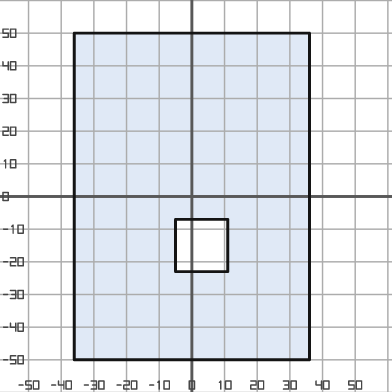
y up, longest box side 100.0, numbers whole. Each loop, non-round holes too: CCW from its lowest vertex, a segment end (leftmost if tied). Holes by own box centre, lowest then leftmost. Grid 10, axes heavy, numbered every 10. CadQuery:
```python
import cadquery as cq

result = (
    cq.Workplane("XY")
    .moveTo(-36.0, -50.0)
    .lineTo(36.0, -50.0)
    .lineTo(36.0, 50.0)
    .lineTo(-36.0, 50.0)
    .close()
    .moveTo(-5.0, -23.0)
    .lineTo(11.0, -23.0)
    .lineTo(11.0, -7.0)
    .lineTo(-5.0, -7.0)
    .close()
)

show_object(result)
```